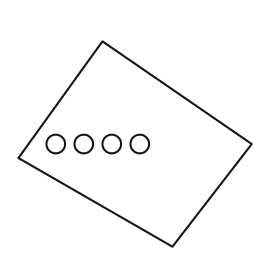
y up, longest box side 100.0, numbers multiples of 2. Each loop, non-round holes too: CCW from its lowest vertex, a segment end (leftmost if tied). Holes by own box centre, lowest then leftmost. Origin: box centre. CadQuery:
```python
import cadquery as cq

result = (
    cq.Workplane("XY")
    .moveTo(16.0, -44.0)
    .lineTo(50.0, 0.0)
    .lineTo(-14.0, 44.0)
    .lineTo(-50.0, -6.0)
    .close()
    .moveTo(-34.0, 0.0)
    .circle(4.0)
    .moveTo(-22.0, 0.0)
    .circle(4.0)
    .moveTo(-10.0, 0.0)
    .circle(4.0)
    .moveTo(2.0, 0.0)
    .circle(4.0)
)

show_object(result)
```